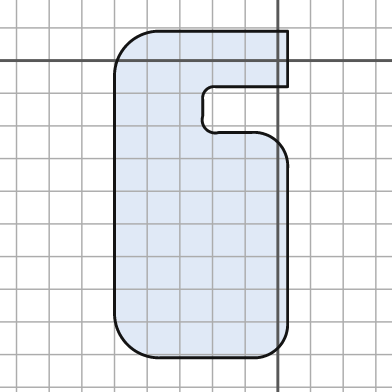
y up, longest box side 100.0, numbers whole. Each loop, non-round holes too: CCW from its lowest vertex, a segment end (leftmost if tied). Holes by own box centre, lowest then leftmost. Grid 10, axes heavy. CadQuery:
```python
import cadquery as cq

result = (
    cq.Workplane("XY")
    .moveTo(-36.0, -91.0)
    .lineTo(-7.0, -91.0)
    .threePointArc((0.0, -88.0), (3.0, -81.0))
    .lineTo(3.0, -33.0)
    .threePointArc((0.0, -25.0), (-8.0, -22.0))
    .lineTo(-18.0, -22.0)
    .threePointArc((-22.0, -21.0), (-23.0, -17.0))
    .lineTo(-23.0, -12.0)
    .threePointArc((-22.0, -9.0), (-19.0, -8.0))
    .lineTo(3.0, -8.0)
    .lineTo(3.0, 9.0)
    .lineTo(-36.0, 9.0)
    .threePointArc((-46.0, 5.0), (-50.0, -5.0))
    .lineTo(-50.0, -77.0)
    .threePointArc((-46.0, -87.0), (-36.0, -91.0))
    .close()
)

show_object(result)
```